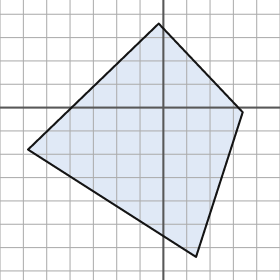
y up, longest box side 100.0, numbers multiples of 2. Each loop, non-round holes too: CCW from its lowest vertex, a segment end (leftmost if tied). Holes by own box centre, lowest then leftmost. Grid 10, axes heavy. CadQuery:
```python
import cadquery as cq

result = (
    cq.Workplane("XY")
    .moveTo(14.0, -64.0)
    .lineTo(34.0, -2.0)
    .lineTo(-2.0, 36.0)
    .lineTo(-58.0, -18.0)
    .close()
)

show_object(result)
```